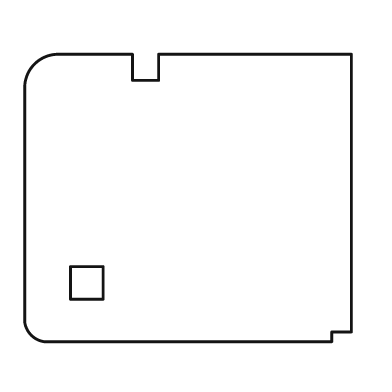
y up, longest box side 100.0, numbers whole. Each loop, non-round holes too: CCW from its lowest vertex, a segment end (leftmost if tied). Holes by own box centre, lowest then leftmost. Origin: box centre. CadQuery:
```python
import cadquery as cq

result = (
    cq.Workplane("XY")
    .moveTo(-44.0, -44.0)
    .lineTo(44.0, -44.0)
    .lineTo(44.0, -41.0)
    .lineTo(50.0, -41.0)
    .lineTo(50.0, 44.0)
    .lineTo(-9.0, 44.0)
    .lineTo(-9.0, 36.0)
    .lineTo(-17.0, 36.0)
    .lineTo(-17.0, 44.0)
    .lineTo(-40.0, 44.0)
    .threePointArc((-47.0, 41.0), (-50.0, 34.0))
    .lineTo(-50.0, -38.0)
    .threePointArc((-48.0, -42.0), (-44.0, -44.0))
    .close()
    .moveTo(-36.0, -31.0)
    .lineTo(-26.0, -31.0)
    .lineTo(-26.0, -21.0)
    .lineTo(-36.0, -21.0)
    .close()
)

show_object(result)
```